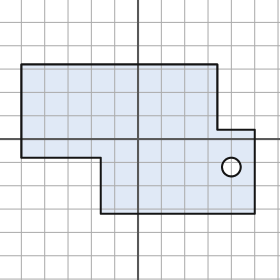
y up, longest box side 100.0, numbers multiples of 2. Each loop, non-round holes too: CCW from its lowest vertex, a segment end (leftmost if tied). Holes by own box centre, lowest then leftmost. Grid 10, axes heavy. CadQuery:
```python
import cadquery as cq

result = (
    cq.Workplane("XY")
    .moveTo(-16.0, -32.0)
    .lineTo(50.0, -32.0)
    .lineTo(50.0, 4.0)
    .lineTo(34.0, 4.0)
    .lineTo(34.0, 32.0)
    .lineTo(-50.0, 32.0)
    .lineTo(-50.0, -8.0)
    .lineTo(-16.0, -8.0)
    .close()
    .moveTo(40.0, -12.0)
    .circle(4.0)
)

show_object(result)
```